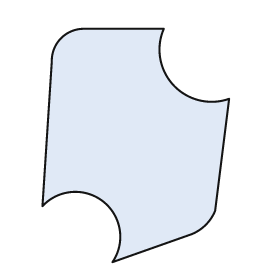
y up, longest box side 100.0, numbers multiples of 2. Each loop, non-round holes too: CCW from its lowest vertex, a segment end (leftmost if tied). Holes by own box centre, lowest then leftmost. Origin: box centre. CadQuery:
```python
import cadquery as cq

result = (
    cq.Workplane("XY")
    .moveTo(-10.0, -50.0)
    .lineTo(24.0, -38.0)
    .threePointArc((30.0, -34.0), (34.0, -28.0))
    .lineTo(40.0, 20.0)
    .threePointArc((16.0, 26.0), (12.0, 50.0))
    .lineTo(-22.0, 50.0)
    .threePointArc((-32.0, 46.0), (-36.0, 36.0))
    .lineTo(-40.0, -26.0)
    .threePointArc((-14.0, -24.0), (-10.0, -50.0))
    .close()
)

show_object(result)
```